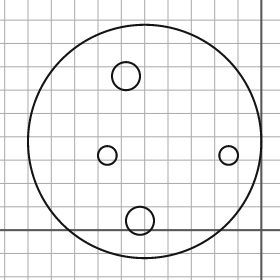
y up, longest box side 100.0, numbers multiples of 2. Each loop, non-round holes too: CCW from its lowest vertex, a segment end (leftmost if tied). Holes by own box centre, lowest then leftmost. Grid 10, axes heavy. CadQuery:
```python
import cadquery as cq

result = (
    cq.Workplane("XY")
    .moveTo(-50.0, 38.0)
    .circle(50.0)
    .moveTo(-52.0, 4.0)
    .circle(6.0)
    .moveTo(-66.0, 32.0)
    .circle(4.0)
    .moveTo(-14.0, 32.0)
    .circle(4.0)
    .moveTo(-58.0, 66.0)
    .circle(6.0)
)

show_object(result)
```